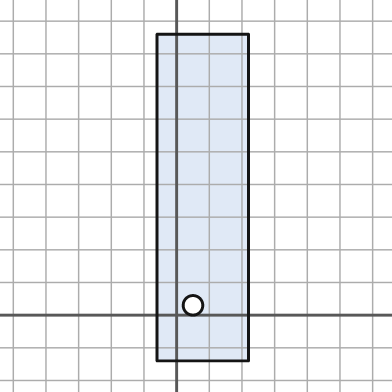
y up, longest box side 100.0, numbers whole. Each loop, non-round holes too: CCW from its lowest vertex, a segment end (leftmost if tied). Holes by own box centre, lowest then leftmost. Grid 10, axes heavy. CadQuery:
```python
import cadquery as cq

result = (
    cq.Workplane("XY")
    .moveTo(-6.0, -14.0)
    .lineTo(22.0, -14.0)
    .lineTo(22.0, 86.0)
    .lineTo(-6.0, 86.0)
    .close()
    .moveTo(5.0, 3.0)
    .circle(3.0)
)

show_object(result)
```